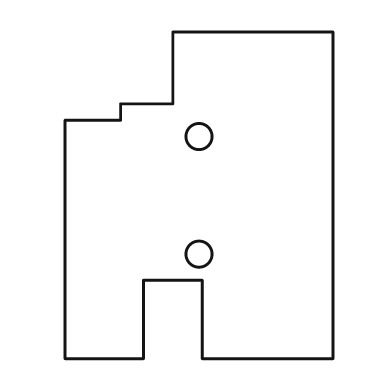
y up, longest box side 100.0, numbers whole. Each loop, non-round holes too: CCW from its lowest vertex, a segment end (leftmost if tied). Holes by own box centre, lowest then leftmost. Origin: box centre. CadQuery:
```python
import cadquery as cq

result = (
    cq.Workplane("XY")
    .moveTo(-41.0, -50.0)
    .lineTo(-17.0, -50.0)
    .lineTo(-17.0, -26.0)
    .lineTo(1.0, -26.0)
    .lineTo(1.0, -50.0)
    .lineTo(41.0, -50.0)
    .lineTo(41.0, 50.0)
    .lineTo(-8.0, 50.0)
    .lineTo(-8.0, 28.0)
    .lineTo(-24.0, 28.0)
    .lineTo(-24.0, 23.0)
    .lineTo(-41.0, 23.0)
    .close()
    .moveTo(0.0, -18.0)
    .circle(4.0)
    .moveTo(0.0, 18.0)
    .circle(4.0)
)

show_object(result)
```